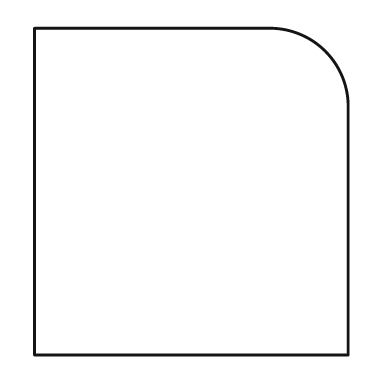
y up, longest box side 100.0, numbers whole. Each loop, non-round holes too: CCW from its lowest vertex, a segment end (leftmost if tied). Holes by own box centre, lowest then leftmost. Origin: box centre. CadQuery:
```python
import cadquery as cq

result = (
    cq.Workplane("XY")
    .moveTo(-48.0, -50.0)
    .lineTo(48.0, -50.0)
    .lineTo(48.0, 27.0)
    .threePointArc((41.0, 43.0), (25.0, 50.0))
    .lineTo(-48.0, 50.0)
    .close()
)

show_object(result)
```